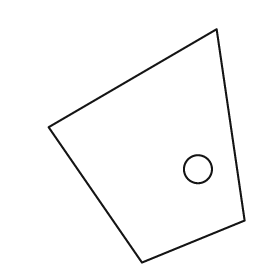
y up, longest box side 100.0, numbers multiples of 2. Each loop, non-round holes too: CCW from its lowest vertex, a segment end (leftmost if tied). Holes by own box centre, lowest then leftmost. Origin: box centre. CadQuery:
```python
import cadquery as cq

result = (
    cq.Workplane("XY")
    .moveTo(-2.0, -50.0)
    .lineTo(42.0, -32.0)
    .lineTo(30.0, 50.0)
    .lineTo(-42.0, 8.0)
    .close()
    .moveTo(22.0, -10.0)
    .circle(6.0)
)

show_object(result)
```